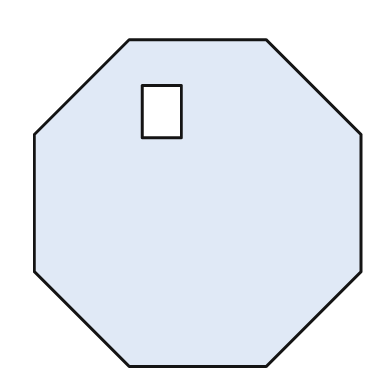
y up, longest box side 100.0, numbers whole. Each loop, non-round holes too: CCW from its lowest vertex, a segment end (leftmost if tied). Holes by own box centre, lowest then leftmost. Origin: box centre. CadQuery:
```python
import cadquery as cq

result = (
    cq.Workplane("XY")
    .moveTo(-21.0, -50.0)
    .lineTo(21.0, -50.0)
    .lineTo(50.0, -21.0)
    .lineTo(50.0, 21.0)
    .lineTo(21.0, 50.0)
    .lineTo(-21.0, 50.0)
    .lineTo(-50.0, 21.0)
    .lineTo(-50.0, -21.0)
    .close()
    .moveTo(-17.0, 20.0)
    .lineTo(-5.0, 20.0)
    .lineTo(-5.0, 36.0)
    .lineTo(-17.0, 36.0)
    .close()
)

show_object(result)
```